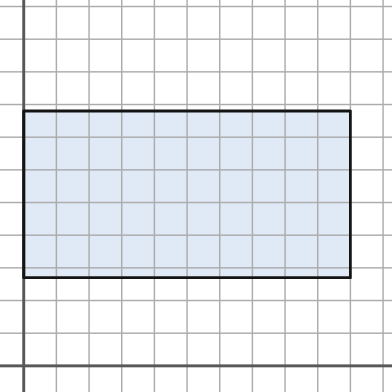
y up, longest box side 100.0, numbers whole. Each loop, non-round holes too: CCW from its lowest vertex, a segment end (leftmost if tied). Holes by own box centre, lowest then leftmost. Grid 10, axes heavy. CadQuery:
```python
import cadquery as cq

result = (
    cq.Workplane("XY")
    .moveTo(0.0, 27.0)
    .lineTo(100.0, 27.0)
    .lineTo(100.0, 78.0)
    .lineTo(0.0, 78.0)
    .close()
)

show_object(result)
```